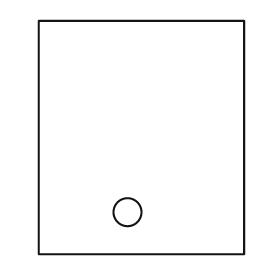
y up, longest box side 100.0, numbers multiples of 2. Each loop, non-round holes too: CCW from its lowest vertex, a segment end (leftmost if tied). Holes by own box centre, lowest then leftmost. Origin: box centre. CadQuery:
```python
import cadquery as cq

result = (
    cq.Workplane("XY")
    .moveTo(-44.0, -50.0)
    .lineTo(44.0, -50.0)
    .lineTo(44.0, 50.0)
    .lineTo(-44.0, 50.0)
    .close()
    .moveTo(-6.0, -32.0)
    .circle(6.0)
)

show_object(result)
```